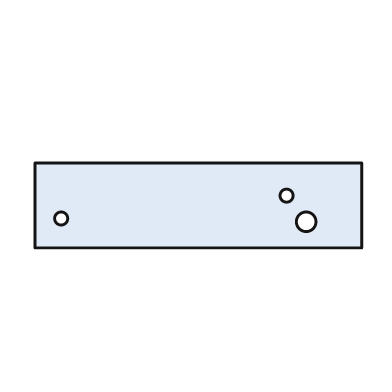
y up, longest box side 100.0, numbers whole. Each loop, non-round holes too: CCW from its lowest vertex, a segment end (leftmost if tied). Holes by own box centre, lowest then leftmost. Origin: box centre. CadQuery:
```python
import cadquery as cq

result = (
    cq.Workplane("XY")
    .moveTo(-50.0, -13.0)
    .lineTo(50.0, -13.0)
    .lineTo(50.0, 13.0)
    .lineTo(-50.0, 13.0)
    .close()
    .moveTo(33.0, -5.0)
    .circle(3.0)
    .moveTo(-42.0, -4.0)
    .circle(2.0)
    .moveTo(27.0, 3.0)
    .circle(2.0)
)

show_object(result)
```